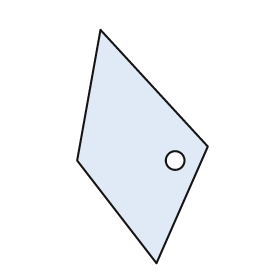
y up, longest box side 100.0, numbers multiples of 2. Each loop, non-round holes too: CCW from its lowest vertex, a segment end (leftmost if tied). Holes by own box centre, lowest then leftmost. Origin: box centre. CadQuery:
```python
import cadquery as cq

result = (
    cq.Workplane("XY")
    .moveTo(6.0, -50.0)
    .lineTo(28.0, 0.0)
    .lineTo(-18.0, 50.0)
    .lineTo(-28.0, -6.0)
    .close()
    .moveTo(14.0, -6.0)
    .circle(4.0)
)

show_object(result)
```